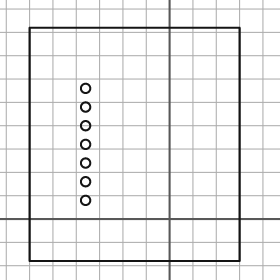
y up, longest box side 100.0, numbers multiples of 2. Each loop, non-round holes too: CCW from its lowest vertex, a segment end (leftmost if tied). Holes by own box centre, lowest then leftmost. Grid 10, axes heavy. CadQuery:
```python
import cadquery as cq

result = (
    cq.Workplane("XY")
    .moveTo(-60.0, -18.0)
    .lineTo(30.0, -18.0)
    .lineTo(30.0, 82.0)
    .lineTo(-60.0, 82.0)
    .close()
    .moveTo(-36.0, 8.0)
    .circle(2.0)
    .moveTo(-36.0, 16.0)
    .circle(2.0)
    .moveTo(-36.0, 24.0)
    .circle(2.0)
    .moveTo(-36.0, 32.0)
    .circle(2.0)
    .moveTo(-36.0, 40.0)
    .circle(2.0)
    .moveTo(-36.0, 48.0)
    .circle(2.0)
    .moveTo(-36.0, 56.0)
    .circle(2.0)
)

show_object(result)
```